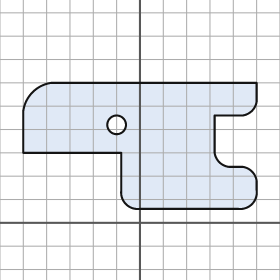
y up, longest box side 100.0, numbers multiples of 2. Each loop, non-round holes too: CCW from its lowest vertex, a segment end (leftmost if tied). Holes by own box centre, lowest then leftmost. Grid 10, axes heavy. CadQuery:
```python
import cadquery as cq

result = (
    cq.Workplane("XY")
    .moveTo(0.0, 6.0)
    .lineTo(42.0, 6.0)
    .threePointArc((48.0, 8.0), (50.0, 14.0))
    .lineTo(50.0, 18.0)
    .threePointArc((48.0, 22.0), (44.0, 24.0))
    .lineTo(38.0, 24.0)
    .threePointArc((34.0, 26.0), (32.0, 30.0))
    .lineTo(32.0, 46.0)
    .lineTo(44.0, 46.0)
    .threePointArc((48.0, 48.0), (50.0, 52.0))
    .lineTo(50.0, 60.0)
    .lineTo(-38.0, 60.0)
    .threePointArc((-46.0, 56.0), (-50.0, 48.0))
    .lineTo(-50.0, 30.0)
    .lineTo(-8.0, 30.0)
    .lineTo(-8.0, 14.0)
    .threePointArc((-6.0, 8.0), (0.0, 6.0))
    .close()
    .moveTo(-10.0, 42.0)
    .circle(4.0)
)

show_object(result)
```